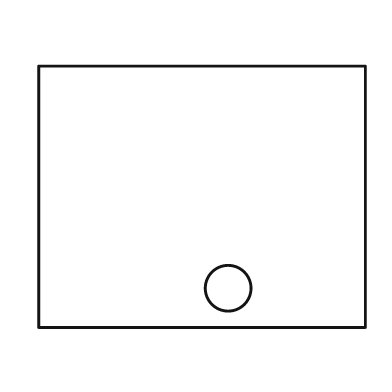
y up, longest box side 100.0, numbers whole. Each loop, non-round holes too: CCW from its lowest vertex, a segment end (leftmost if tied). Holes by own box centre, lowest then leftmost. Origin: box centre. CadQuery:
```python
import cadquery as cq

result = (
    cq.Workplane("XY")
    .moveTo(-50.0, -40.0)
    .lineTo(50.0, -40.0)
    .lineTo(50.0, 40.0)
    .lineTo(-50.0, 40.0)
    .close()
    .moveTo(8.0, -28.0)
    .circle(7.0)
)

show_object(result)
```